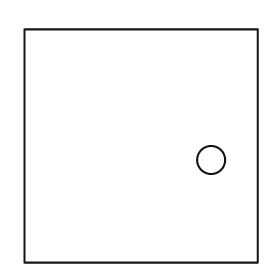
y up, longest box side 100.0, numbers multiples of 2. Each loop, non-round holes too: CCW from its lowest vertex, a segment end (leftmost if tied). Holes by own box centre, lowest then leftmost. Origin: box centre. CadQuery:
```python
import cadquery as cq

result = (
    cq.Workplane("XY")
    .moveTo(-50.0, -50.0)
    .lineTo(50.0, -50.0)
    .lineTo(50.0, 50.0)
    .lineTo(-50.0, 50.0)
    .close()
    .moveTo(30.0, -6.0)
    .circle(6.0)
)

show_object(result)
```